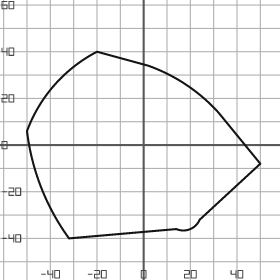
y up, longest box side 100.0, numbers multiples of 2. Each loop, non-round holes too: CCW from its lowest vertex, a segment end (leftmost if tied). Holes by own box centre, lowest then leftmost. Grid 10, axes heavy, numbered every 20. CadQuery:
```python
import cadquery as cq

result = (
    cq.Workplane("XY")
    .moveTo(-32.0, -40.0)
    .lineTo(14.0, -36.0)
    .threePointArc((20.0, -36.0), (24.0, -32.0))
    .lineTo(50.0, -8.0)
    .lineTo(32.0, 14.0)
    .threePointArc((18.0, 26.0), (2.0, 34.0))
    .lineTo(-20.0, 40.0)
    .threePointArc((-38.0, 26.0), (-50.0, 6.0))
    .threePointArc((-44.0, -18.0), (-32.0, -40.0))
    .close()
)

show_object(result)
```